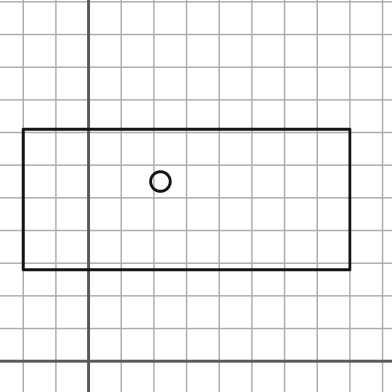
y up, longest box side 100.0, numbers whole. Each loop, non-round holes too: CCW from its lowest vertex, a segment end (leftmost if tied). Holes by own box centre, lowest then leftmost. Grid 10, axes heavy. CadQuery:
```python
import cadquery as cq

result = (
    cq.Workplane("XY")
    .moveTo(-20.0, 28.0)
    .lineTo(80.0, 28.0)
    .lineTo(80.0, 71.0)
    .lineTo(-20.0, 71.0)
    .close()
    .moveTo(22.0, 55.0)
    .circle(3.0)
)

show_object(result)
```